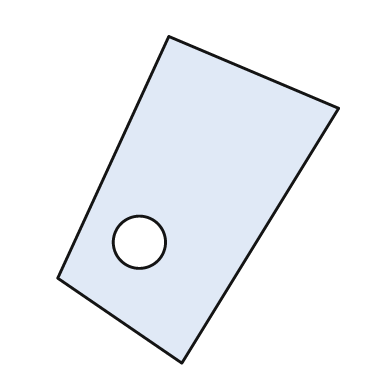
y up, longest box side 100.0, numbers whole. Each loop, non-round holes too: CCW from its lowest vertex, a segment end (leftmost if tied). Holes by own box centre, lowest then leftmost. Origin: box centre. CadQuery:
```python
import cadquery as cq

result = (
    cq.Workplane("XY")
    .moveTo(-5.0, -50.0)
    .lineTo(43.0, 28.0)
    .lineTo(-9.0, 50.0)
    .lineTo(-43.0, -24.0)
    .close()
    .moveTo(-18.0, -13.0)
    .circle(8.0)
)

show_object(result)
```